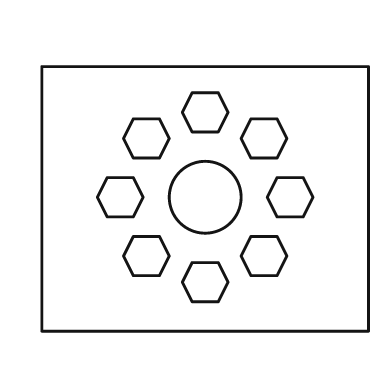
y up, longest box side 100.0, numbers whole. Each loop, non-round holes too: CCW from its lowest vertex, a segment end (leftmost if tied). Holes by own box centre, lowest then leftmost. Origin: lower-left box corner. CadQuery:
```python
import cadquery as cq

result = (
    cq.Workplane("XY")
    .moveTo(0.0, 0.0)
    .lineTo(100.0, 0.0)
    .lineTo(100.0, 81.0)
    .lineTo(0.0, 81.0)
    .close()
    .moveTo(46.0, 9.0)
    .lineTo(54.0, 9.0)
    .lineTo(57.0, 15.0)
    .lineTo(54.0, 21.0)
    .lineTo(46.0, 21.0)
    .lineTo(43.0, 15.0)
    .close()
    .moveTo(28.0, 17.0)
    .lineTo(36.0, 17.0)
    .lineTo(39.0, 23.0)
    .lineTo(36.0, 29.0)
    .lineTo(28.0, 29.0)
    .lineTo(25.0, 23.0)
    .close()
    .moveTo(64.0, 17.0)
    .lineTo(72.0, 17.0)
    .lineTo(75.0, 23.0)
    .lineTo(72.0, 29.0)
    .lineTo(64.0, 29.0)
    .lineTo(61.0, 23.0)
    .close()
    .moveTo(20.0, 35.0)
    .lineTo(28.0, 35.0)
    .lineTo(31.0, 41.0)
    .lineTo(28.0, 47.0)
    .lineTo(20.0, 47.0)
    .lineTo(17.0, 41.0)
    .close()
    .moveTo(50.0, 41.0)
    .circle(11.0)
    .moveTo(72.0, 35.0)
    .lineTo(80.0, 35.0)
    .lineTo(83.0, 41.0)
    .lineTo(80.0, 47.0)
    .lineTo(72.0, 47.0)
    .lineTo(69.0, 41.0)
    .close()
    .moveTo(28.0, 53.0)
    .lineTo(36.0, 53.0)
    .lineTo(39.0, 59.0)
    .lineTo(36.0, 65.0)
    .lineTo(28.0, 65.0)
    .lineTo(25.0, 59.0)
    .close()
    .moveTo(64.0, 53.0)
    .lineTo(72.0, 53.0)
    .lineTo(75.0, 59.0)
    .lineTo(72.0, 65.0)
    .lineTo(64.0, 65.0)
    .lineTo(61.0, 59.0)
    .close()
    .moveTo(46.0, 61.0)
    .lineTo(54.0, 61.0)
    .lineTo(57.0, 67.0)
    .lineTo(54.0, 73.0)
    .lineTo(46.0, 73.0)
    .lineTo(43.0, 67.0)
    .close()
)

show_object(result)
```